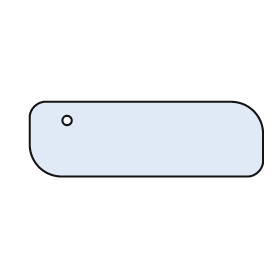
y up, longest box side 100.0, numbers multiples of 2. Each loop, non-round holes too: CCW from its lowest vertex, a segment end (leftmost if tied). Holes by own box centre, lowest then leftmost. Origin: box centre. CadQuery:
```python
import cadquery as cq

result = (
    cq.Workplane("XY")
    .moveTo(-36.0, -16.0)
    .lineTo(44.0, -16.0)
    .threePointArc((48.0, -14.0), (50.0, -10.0))
    .lineTo(50.0, 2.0)
    .threePointArc((46.0, 12.0), (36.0, 16.0))
    .lineTo(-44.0, 16.0)
    .threePointArc((-48.0, 14.0), (-50.0, 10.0))
    .lineTo(-50.0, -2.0)
    .threePointArc((-46.0, -12.0), (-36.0, -16.0))
    .close()
    .moveTo(-34.0, 8.0)
    .circle(2.0)
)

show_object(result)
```